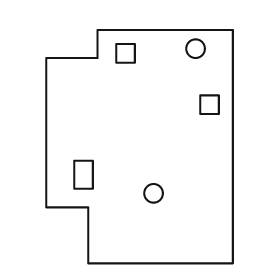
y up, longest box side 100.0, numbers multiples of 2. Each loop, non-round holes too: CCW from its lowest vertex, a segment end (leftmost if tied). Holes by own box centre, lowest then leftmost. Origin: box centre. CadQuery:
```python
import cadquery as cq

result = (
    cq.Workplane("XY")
    .moveTo(-22.0, -50.0)
    .lineTo(40.0, -50.0)
    .lineTo(40.0, 50.0)
    .lineTo(-18.0, 50.0)
    .lineTo(-18.0, 38.0)
    .lineTo(-40.0, 38.0)
    .lineTo(-40.0, -26.0)
    .lineTo(-22.0, -26.0)
    .close()
    .moveTo(6.0, -20.0)
    .circle(4.0)
    .moveTo(-28.0, -18.0)
    .lineTo(-20.0, -18.0)
    .lineTo(-20.0, -6.0)
    .lineTo(-28.0, -6.0)
    .close()
    .moveTo(26.0, 14.0)
    .lineTo(34.0, 14.0)
    .lineTo(34.0, 22.0)
    .lineTo(26.0, 22.0)
    .close()
    .moveTo(-10.0, 36.0)
    .lineTo(-2.0, 36.0)
    .lineTo(-2.0, 44.0)
    .lineTo(-10.0, 44.0)
    .close()
    .moveTo(24.0, 42.0)
    .circle(4.0)
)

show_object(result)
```